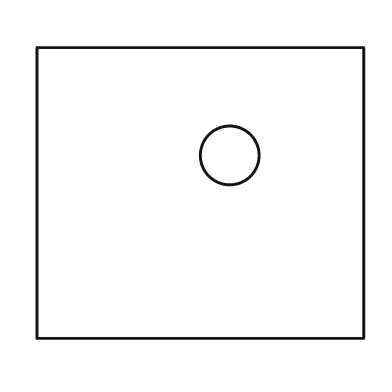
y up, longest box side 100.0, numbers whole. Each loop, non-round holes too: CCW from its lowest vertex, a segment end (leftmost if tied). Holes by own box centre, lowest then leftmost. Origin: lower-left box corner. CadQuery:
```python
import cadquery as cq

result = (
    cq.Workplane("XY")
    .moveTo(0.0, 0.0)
    .lineTo(100.0, 0.0)
    .lineTo(100.0, 89.0)
    .lineTo(0.0, 89.0)
    .close()
    .moveTo(59.0, 56.0)
    .circle(9.0)
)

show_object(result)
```